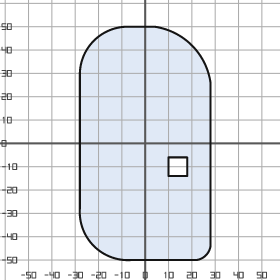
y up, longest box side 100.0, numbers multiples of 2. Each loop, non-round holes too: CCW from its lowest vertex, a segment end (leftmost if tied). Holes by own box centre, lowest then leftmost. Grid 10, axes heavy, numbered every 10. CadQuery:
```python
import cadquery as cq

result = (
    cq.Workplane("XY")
    .moveTo(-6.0, -50.0)
    .lineTo(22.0, -50.0)
    .threePointArc((26.0, -48.0), (28.0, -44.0))
    .lineTo(28.0, 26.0)
    .threePointArc((20.0, 42.0), (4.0, 50.0))
    .lineTo(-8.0, 50.0)
    .threePointArc((-22.0, 44.0), (-28.0, 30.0))
    .lineTo(-28.0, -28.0)
    .threePointArc((-22.0, -44.0), (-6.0, -50.0))
    .close()
    .moveTo(10.0, -14.0)
    .lineTo(18.0, -14.0)
    .lineTo(18.0, -6.0)
    .lineTo(10.0, -6.0)
    .close()
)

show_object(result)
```